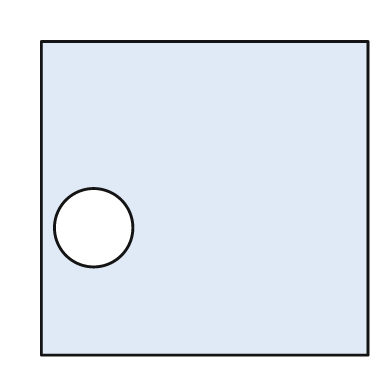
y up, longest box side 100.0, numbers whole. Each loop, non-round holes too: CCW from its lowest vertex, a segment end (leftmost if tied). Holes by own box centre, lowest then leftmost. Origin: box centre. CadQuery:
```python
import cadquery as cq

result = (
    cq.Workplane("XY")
    .moveTo(-50.0, -48.0)
    .lineTo(50.0, -48.0)
    .lineTo(50.0, 48.0)
    .lineTo(-50.0, 48.0)
    .close()
    .moveTo(-34.0, -9.0)
    .circle(12.0)
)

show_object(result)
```